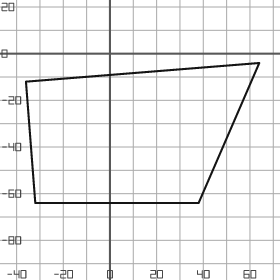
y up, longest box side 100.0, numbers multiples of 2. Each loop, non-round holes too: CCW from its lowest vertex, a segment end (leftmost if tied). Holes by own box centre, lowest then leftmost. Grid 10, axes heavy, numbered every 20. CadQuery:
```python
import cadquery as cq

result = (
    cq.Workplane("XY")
    .moveTo(-32.0, -64.0)
    .lineTo(38.0, -64.0)
    .lineTo(64.0, -4.0)
    .lineTo(-36.0, -12.0)
    .close()
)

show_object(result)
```